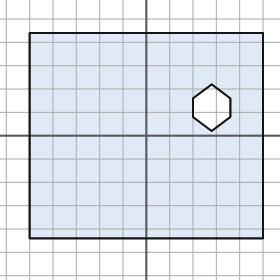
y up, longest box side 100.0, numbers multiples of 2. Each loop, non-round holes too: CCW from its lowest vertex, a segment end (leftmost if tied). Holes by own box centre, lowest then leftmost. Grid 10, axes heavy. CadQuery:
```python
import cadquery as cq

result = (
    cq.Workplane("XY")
    .moveTo(-50.0, -44.0)
    .lineTo(50.0, -44.0)
    .lineTo(50.0, 44.0)
    .lineTo(-50.0, 44.0)
    .close()
    .moveTo(28.0, 2.0)
    .lineTo(36.0, 8.0)
    .lineTo(36.0, 16.0)
    .lineTo(28.0, 22.0)
    .lineTo(20.0, 16.0)
    .lineTo(20.0, 8.0)
    .close()
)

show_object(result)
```